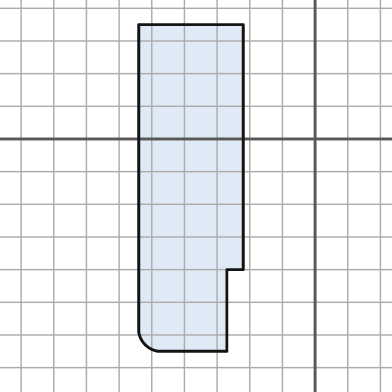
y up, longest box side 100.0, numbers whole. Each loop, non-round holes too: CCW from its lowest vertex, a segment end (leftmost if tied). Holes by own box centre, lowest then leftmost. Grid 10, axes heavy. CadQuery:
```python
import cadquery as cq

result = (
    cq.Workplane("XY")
    .moveTo(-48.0, -65.0)
    .lineTo(-27.0, -65.0)
    .lineTo(-27.0, -40.0)
    .lineTo(-22.0, -40.0)
    .lineTo(-22.0, 35.0)
    .lineTo(-54.0, 35.0)
    .lineTo(-54.0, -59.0)
    .threePointArc((-52.0, -63.0), (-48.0, -65.0))
    .close()
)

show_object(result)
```